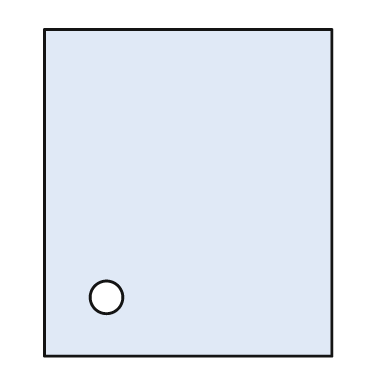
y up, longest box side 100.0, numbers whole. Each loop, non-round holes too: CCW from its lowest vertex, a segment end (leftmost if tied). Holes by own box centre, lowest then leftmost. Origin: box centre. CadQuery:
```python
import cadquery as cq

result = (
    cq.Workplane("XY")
    .moveTo(-44.0, -50.0)
    .lineTo(44.0, -50.0)
    .lineTo(44.0, 50.0)
    .lineTo(-44.0, 50.0)
    .close()
    .moveTo(-25.0, -32.0)
    .circle(5.0)
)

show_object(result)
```